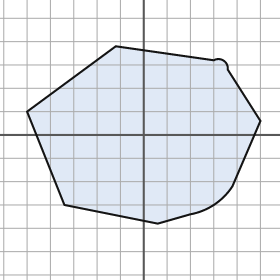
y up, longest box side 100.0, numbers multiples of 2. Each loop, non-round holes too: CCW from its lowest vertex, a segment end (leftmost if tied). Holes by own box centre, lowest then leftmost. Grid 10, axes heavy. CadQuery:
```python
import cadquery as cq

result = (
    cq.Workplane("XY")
    .moveTo(6.0, -38.0)
    .lineTo(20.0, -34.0)
    .threePointArc((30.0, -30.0), (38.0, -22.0))
    .lineTo(50.0, 6.0)
    .lineTo(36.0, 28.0)
    .threePointArc((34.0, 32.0), (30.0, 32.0))
    .lineTo(-12.0, 38.0)
    .lineTo(-50.0, 10.0)
    .lineTo(-34.0, -30.0)
    .close()
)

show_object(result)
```